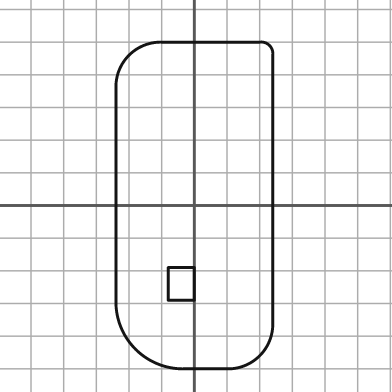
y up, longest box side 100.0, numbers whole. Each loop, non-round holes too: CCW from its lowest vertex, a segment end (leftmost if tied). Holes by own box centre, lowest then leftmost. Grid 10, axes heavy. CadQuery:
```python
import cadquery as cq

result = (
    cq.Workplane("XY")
    .moveTo(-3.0, -50.0)
    .lineTo(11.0, -50.0)
    .threePointArc((20.0, -46.0), (24.0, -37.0))
    .lineTo(24.0, 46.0)
    .threePointArc((23.0, 49.0), (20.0, 50.0))
    .lineTo(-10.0, 50.0)
    .threePointArc((-20.0, 46.0), (-24.0, 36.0))
    .lineTo(-24.0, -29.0)
    .threePointArc((-18.0, -44.0), (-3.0, -50.0))
    .close()
    .moveTo(-8.0, -29.0)
    .lineTo(0.0, -29.0)
    .lineTo(0.0, -19.0)
    .lineTo(-8.0, -19.0)
    .close()
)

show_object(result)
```